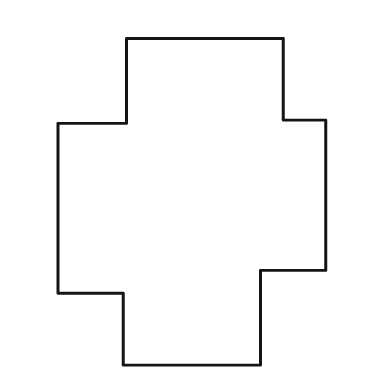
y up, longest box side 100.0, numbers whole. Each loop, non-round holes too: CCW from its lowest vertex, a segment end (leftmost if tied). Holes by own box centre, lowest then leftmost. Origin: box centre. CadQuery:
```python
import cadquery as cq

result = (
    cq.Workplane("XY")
    .moveTo(-21.0, -50.0)
    .lineTo(21.0, -50.0)
    .lineTo(21.0, -21.0)
    .lineTo(41.0, -21.0)
    .lineTo(41.0, 25.0)
    .lineTo(28.0, 25.0)
    .lineTo(28.0, 50.0)
    .lineTo(-20.0, 50.0)
    .lineTo(-20.0, 24.0)
    .lineTo(-41.0, 24.0)
    .lineTo(-41.0, -28.0)
    .lineTo(-21.0, -28.0)
    .close()
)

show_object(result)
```